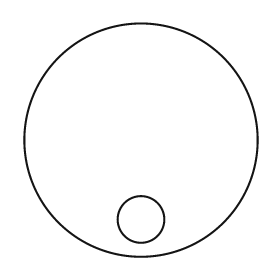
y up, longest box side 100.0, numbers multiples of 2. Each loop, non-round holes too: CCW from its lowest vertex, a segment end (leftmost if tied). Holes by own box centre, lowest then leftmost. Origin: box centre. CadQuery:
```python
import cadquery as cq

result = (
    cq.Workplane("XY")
    .moveTo(0.0, 0.0)
    .circle(50.0)
    .moveTo(0.0, -34.0)
    .circle(10.0)
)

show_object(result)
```